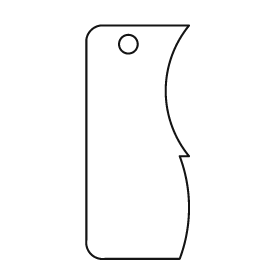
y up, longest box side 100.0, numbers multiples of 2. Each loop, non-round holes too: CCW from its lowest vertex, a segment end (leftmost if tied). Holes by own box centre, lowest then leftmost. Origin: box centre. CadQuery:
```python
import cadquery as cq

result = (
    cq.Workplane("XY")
    .moveTo(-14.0, -50.0)
    .lineTo(18.0, -50.0)
    .threePointArc((22.0, -28.0), (18.0, -6.0))
    .lineTo(22.0, -6.0)
    .threePointArc((12.0, 22.0), (22.0, 50.0))
    .lineTo(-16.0, 50.0)
    .threePointArc((-20.0, 48.0), (-22.0, 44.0))
    .lineTo(-22.0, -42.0)
    .threePointArc((-20.0, -48.0), (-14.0, -50.0))
    .close()
    .moveTo(-4.0, 42.0)
    .circle(4.0)
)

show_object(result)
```